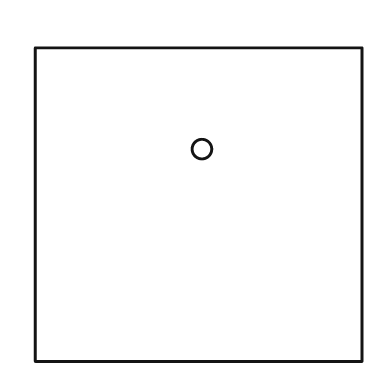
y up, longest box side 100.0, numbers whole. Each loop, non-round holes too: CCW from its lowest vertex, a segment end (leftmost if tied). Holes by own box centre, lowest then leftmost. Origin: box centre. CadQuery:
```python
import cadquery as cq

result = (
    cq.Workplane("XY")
    .moveTo(-50.0, -48.0)
    .lineTo(50.0, -48.0)
    .lineTo(50.0, 48.0)
    .lineTo(-50.0, 48.0)
    .close()
    .moveTo(1.0, 17.0)
    .circle(3.0)
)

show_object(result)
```